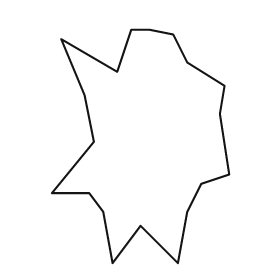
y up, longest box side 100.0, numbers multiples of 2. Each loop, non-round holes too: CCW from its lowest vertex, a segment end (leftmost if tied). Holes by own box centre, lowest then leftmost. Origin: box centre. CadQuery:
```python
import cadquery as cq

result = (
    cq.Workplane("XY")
    .moveTo(-12.0, -50.0)
    .lineTo(0.0, -34.0)
    .lineTo(16.0, -50.0)
    .lineTo(20.0, -28.0)
    .lineTo(26.0, -16.0)
    .lineTo(38.0, -12.0)
    .lineTo(34.0, 14.0)
    .lineTo(36.0, 26.0)
    .lineTo(20.0, 36.0)
    .lineTo(14.0, 48.0)
    .lineTo(4.0, 50.0)
    .lineTo(-4.0, 50.0)
    .lineTo(-10.0, 32.0)
    .lineTo(-34.0, 46.0)
    .lineTo(-24.0, 22.0)
    .lineTo(-20.0, 2.0)
    .lineTo(-38.0, -20.0)
    .lineTo(-22.0, -20.0)
    .lineTo(-16.0, -28.0)
    .close()
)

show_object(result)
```